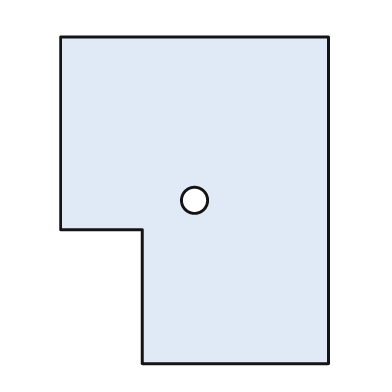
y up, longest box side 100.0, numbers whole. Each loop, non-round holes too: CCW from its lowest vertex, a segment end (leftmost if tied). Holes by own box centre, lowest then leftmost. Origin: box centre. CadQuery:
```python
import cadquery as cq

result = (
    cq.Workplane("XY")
    .moveTo(-16.0, -50.0)
    .lineTo(41.0, -50.0)
    .lineTo(41.0, 50.0)
    .lineTo(-41.0, 50.0)
    .lineTo(-41.0, -9.0)
    .lineTo(-16.0, -9.0)
    .close()
    .moveTo(0.0, 0.0)
    .circle(4.0)
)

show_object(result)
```